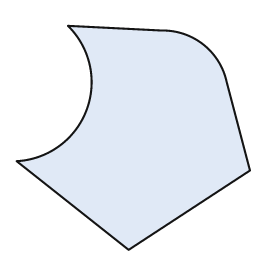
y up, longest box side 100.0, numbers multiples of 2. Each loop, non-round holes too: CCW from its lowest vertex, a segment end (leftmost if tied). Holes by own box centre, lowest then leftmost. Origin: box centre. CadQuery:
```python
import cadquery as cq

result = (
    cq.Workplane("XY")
    .moveTo(-2.0, -48.0)
    .lineTo(50.0, -14.0)
    .lineTo(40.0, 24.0)
    .threePointArc((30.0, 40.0), (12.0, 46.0))
    .lineTo(-28.0, 48.0)
    .threePointArc((-20.0, 12.0), (-50.0, -10.0))
    .close()
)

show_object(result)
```